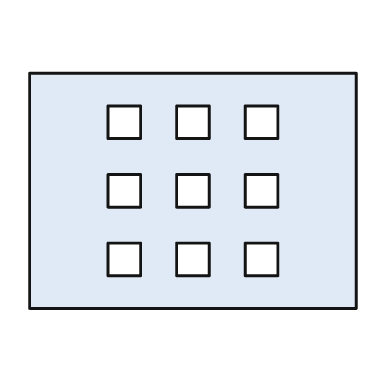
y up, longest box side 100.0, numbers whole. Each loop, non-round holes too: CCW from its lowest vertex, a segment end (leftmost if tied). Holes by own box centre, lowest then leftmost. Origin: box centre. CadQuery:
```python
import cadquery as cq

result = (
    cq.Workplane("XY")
    .moveTo(-50.0, -36.0)
    .lineTo(50.0, -36.0)
    .lineTo(50.0, 36.0)
    .lineTo(-50.0, 36.0)
    .close()
    .moveTo(-26.0, -26.0)
    .lineTo(-16.0, -26.0)
    .lineTo(-16.0, -16.0)
    .lineTo(-26.0, -16.0)
    .close()
    .moveTo(-5.0, -26.0)
    .lineTo(5.0, -26.0)
    .lineTo(5.0, -16.0)
    .lineTo(-5.0, -16.0)
    .close()
    .moveTo(16.0, -26.0)
    .lineTo(26.0, -26.0)
    .lineTo(26.0, -16.0)
    .lineTo(16.0, -16.0)
    .close()
    .moveTo(-26.0, -5.0)
    .lineTo(-16.0, -5.0)
    .lineTo(-16.0, 5.0)
    .lineTo(-26.0, 5.0)
    .close()
    .moveTo(-5.0, -5.0)
    .lineTo(5.0, -5.0)
    .lineTo(5.0, 5.0)
    .lineTo(-5.0, 5.0)
    .close()
    .moveTo(16.0, -5.0)
    .lineTo(26.0, -5.0)
    .lineTo(26.0, 5.0)
    .lineTo(16.0, 5.0)
    .close()
    .moveTo(-26.0, 16.0)
    .lineTo(-16.0, 16.0)
    .lineTo(-16.0, 26.0)
    .lineTo(-26.0, 26.0)
    .close()
    .moveTo(-5.0, 16.0)
    .lineTo(5.0, 16.0)
    .lineTo(5.0, 26.0)
    .lineTo(-5.0, 26.0)
    .close()
    .moveTo(16.0, 16.0)
    .lineTo(26.0, 16.0)
    .lineTo(26.0, 26.0)
    .lineTo(16.0, 26.0)
    .close()
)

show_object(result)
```